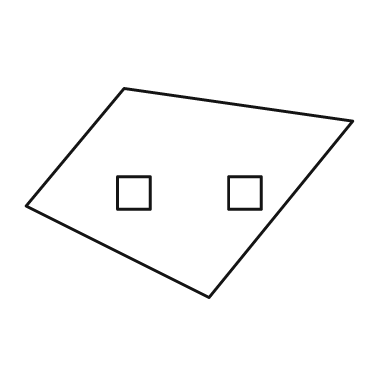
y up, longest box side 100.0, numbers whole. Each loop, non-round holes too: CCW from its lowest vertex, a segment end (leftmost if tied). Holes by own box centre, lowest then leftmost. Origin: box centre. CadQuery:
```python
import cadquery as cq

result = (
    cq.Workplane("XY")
    .moveTo(6.0, -32.0)
    .lineTo(50.0, 22.0)
    .lineTo(-20.0, 32.0)
    .lineTo(-50.0, -4.0)
    .close()
    .moveTo(-22.0, -5.0)
    .lineTo(-12.0, -5.0)
    .lineTo(-12.0, 5.0)
    .lineTo(-22.0, 5.0)
    .close()
    .moveTo(12.0, -5.0)
    .lineTo(22.0, -5.0)
    .lineTo(22.0, 5.0)
    .lineTo(12.0, 5.0)
    .close()
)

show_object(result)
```